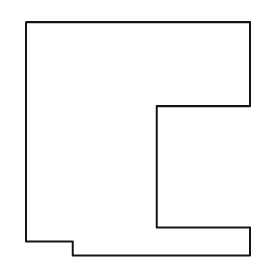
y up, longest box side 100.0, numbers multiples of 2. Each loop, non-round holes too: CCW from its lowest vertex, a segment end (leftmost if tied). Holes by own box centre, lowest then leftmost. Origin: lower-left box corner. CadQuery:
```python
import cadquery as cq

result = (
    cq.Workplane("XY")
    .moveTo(20.0, 0.0)
    .lineTo(96.0, 0.0)
    .lineTo(96.0, 12.0)
    .lineTo(56.0, 12.0)
    .lineTo(56.0, 64.0)
    .lineTo(96.0, 64.0)
    .lineTo(96.0, 100.0)
    .lineTo(0.0, 100.0)
    .lineTo(0.0, 6.0)
    .lineTo(20.0, 6.0)
    .close()
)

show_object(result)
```